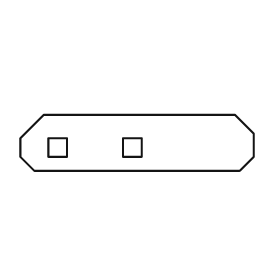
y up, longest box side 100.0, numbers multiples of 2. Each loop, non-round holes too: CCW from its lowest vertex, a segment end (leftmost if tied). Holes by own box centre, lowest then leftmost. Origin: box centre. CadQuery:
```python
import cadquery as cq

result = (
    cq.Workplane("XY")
    .moveTo(-44.0, -12.0)
    .lineTo(44.0, -12.0)
    .lineTo(50.0, -6.0)
    .lineTo(50.0, 4.0)
    .lineTo(42.0, 12.0)
    .lineTo(-40.0, 12.0)
    .lineTo(-50.0, 2.0)
    .lineTo(-50.0, -6.0)
    .close()
    .moveTo(-38.0, -6.0)
    .lineTo(-30.0, -6.0)
    .lineTo(-30.0, 2.0)
    .lineTo(-38.0, 2.0)
    .close()
    .moveTo(-6.0, -6.0)
    .lineTo(2.0, -6.0)
    .lineTo(2.0, 2.0)
    .lineTo(-6.0, 2.0)
    .close()
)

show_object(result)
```